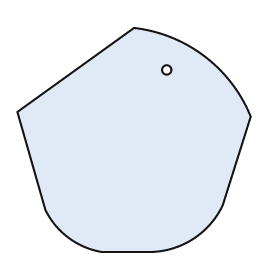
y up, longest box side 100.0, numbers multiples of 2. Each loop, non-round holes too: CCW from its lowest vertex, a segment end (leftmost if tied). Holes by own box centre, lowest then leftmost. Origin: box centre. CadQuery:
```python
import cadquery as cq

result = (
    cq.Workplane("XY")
    .moveTo(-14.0, -48.0)
    .lineTo(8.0, -48.0)
    .threePointArc((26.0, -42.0), (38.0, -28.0))
    .lineTo(50.0, 10.0)
    .threePointArc((30.0, 36.0), (0.0, 48.0))
    .lineTo(-50.0, 12.0)
    .lineTo(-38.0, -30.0)
    .threePointArc((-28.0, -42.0), (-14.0, -48.0))
    .close()
    .moveTo(14.0, 30.0)
    .circle(2.0)
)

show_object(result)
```